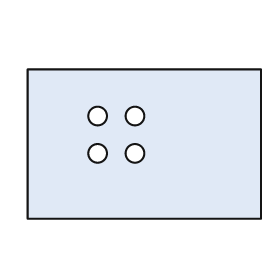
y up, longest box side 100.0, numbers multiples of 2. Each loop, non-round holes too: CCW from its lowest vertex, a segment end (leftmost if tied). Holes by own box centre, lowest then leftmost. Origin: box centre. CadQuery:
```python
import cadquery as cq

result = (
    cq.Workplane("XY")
    .moveTo(-50.0, -32.0)
    .lineTo(50.0, -32.0)
    .lineTo(50.0, 32.0)
    .lineTo(-50.0, 32.0)
    .close()
    .moveTo(-20.0, -4.0)
    .circle(4.0)
    .moveTo(-4.0, -4.0)
    .circle(4.0)
    .moveTo(-20.0, 12.0)
    .circle(4.0)
    .moveTo(-4.0, 12.0)
    .circle(4.0)
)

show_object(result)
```